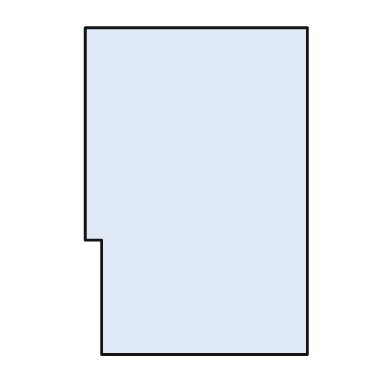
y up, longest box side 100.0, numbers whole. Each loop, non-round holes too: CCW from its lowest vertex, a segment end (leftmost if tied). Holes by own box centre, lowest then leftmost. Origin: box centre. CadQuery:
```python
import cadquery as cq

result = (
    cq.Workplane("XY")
    .moveTo(-29.0, -50.0)
    .lineTo(34.0, -50.0)
    .lineTo(34.0, 50.0)
    .lineTo(-34.0, 50.0)
    .lineTo(-34.0, -15.0)
    .lineTo(-29.0, -15.0)
    .close()
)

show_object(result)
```